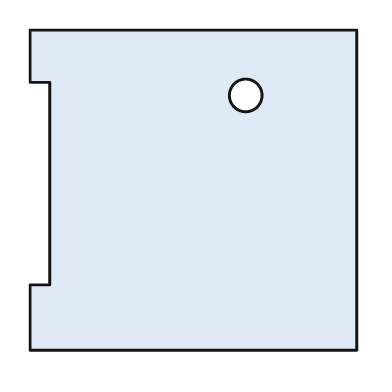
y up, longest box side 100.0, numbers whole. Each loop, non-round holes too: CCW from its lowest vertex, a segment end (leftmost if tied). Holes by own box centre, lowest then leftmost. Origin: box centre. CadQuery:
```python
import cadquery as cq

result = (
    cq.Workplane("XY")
    .moveTo(-50.0, -49.0)
    .lineTo(50.0, -49.0)
    .lineTo(50.0, 49.0)
    .lineTo(-50.0, 49.0)
    .lineTo(-50.0, 33.0)
    .lineTo(-44.0, 33.0)
    .lineTo(-44.0, -29.0)
    .lineTo(-50.0, -29.0)
    .close()
    .moveTo(16.0, 29.0)
    .circle(5.0)
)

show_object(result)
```